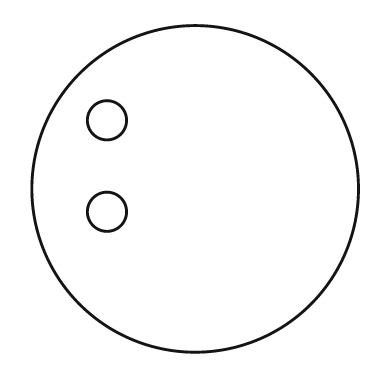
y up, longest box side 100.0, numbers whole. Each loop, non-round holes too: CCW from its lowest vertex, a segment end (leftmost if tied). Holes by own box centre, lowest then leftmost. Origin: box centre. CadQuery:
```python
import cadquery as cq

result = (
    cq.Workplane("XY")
    .moveTo(0.0, 0.0)
    .circle(50.0)
    .moveTo(-27.0, -7.0)
    .circle(6.0)
    .moveTo(-27.0, 21.0)
    .circle(6.0)
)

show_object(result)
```